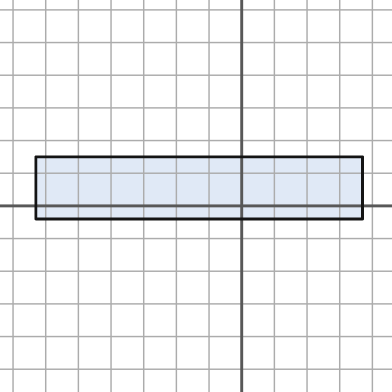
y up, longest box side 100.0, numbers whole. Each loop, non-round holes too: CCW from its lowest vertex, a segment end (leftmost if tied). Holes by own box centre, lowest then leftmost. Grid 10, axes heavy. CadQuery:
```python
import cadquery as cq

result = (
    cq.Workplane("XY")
    .moveTo(-63.0, -4.0)
    .lineTo(37.0, -4.0)
    .lineTo(37.0, 15.0)
    .lineTo(-63.0, 15.0)
    .close()
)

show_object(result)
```